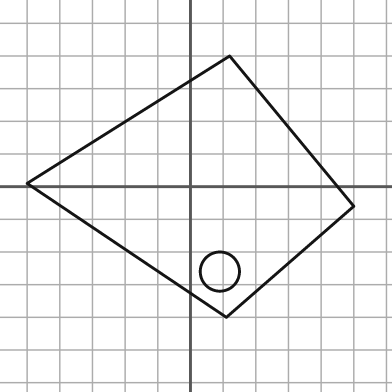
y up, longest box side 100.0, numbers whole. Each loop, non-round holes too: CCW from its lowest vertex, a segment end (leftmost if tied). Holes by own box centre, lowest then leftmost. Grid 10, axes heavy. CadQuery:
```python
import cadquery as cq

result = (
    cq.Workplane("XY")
    .moveTo(11.0, -40.0)
    .lineTo(50.0, -6.0)
    .lineTo(12.0, 40.0)
    .lineTo(-50.0, 1.0)
    .close()
    .moveTo(9.0, -26.0)
    .circle(6.0)
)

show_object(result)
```